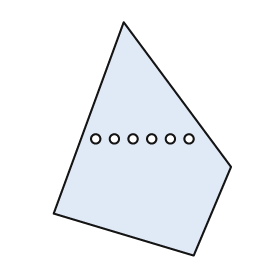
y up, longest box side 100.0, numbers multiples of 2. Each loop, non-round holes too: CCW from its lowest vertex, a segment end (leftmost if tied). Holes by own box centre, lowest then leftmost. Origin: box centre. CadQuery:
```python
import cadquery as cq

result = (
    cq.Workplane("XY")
    .moveTo(22.0, -50.0)
    .lineTo(38.0, -12.0)
    .lineTo(-8.0, 50.0)
    .lineTo(-38.0, -32.0)
    .close()
    .moveTo(-20.0, 0.0)
    .circle(2.0)
    .moveTo(-12.0, 0.0)
    .circle(2.0)
    .moveTo(-4.0, 0.0)
    .circle(2.0)
    .moveTo(4.0, 0.0)
    .circle(2.0)
    .moveTo(12.0, 0.0)
    .circle(2.0)
    .moveTo(20.0, 0.0)
    .circle(2.0)
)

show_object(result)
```